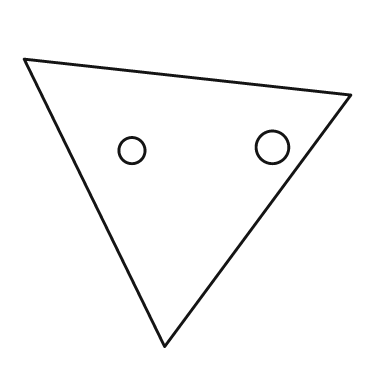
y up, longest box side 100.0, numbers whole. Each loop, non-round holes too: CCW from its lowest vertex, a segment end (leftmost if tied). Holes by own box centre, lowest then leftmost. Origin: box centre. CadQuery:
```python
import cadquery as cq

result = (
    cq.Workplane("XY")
    .moveTo(-7.0, -44.0)
    .lineTo(50.0, 33.0)
    .lineTo(-50.0, 44.0)
    .close()
    .moveTo(-17.0, 16.0)
    .circle(4.0)
    .moveTo(26.0, 17.0)
    .circle(5.0)
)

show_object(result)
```